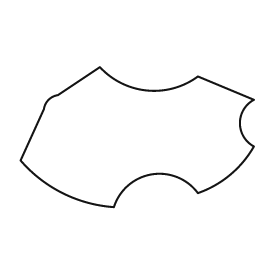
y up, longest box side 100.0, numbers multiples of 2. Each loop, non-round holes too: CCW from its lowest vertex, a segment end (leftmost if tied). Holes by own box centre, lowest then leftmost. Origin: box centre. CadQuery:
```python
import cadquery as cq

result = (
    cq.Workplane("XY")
    .moveTo(-10.0, -30.0)
    .threePointArc((6.0, -16.0), (26.0, -24.0))
    .threePointArc((40.0, -16.0), (50.0, -4.0))
    .threePointArc((44.0, 6.0), (50.0, 16.0))
    .lineTo(26.0, 26.0)
    .threePointArc((4.0, 20.0), (-16.0, 30.0))
    .lineTo(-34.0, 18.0)
    .threePointArc((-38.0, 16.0), (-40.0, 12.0))
    .lineTo(-50.0, -10.0)
    .threePointArc((-32.0, -24.0), (-10.0, -30.0))
    .close()
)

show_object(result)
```